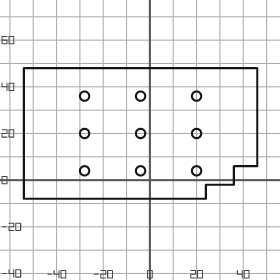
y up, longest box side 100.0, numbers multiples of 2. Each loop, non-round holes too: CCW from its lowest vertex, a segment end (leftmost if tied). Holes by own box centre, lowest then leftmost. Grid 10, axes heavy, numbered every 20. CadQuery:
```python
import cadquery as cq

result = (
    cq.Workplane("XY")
    .moveTo(-54.0, -8.0)
    .lineTo(24.0, -8.0)
    .lineTo(24.0, -2.0)
    .lineTo(36.0, -2.0)
    .lineTo(36.0, 6.0)
    .lineTo(46.0, 6.0)
    .lineTo(46.0, 48.0)
    .lineTo(-54.0, 48.0)
    .close()
    .moveTo(-28.0, 4.0)
    .circle(2.0)
    .moveTo(-4.0, 4.0)
    .circle(2.0)
    .moveTo(20.0, 4.0)
    .circle(2.0)
    .moveTo(-28.0, 20.0)
    .circle(2.0)
    .moveTo(-4.0, 20.0)
    .circle(2.0)
    .moveTo(20.0, 20.0)
    .circle(2.0)
    .moveTo(-28.0, 36.0)
    .circle(2.0)
    .moveTo(-4.0, 36.0)
    .circle(2.0)
    .moveTo(20.0, 36.0)
    .circle(2.0)
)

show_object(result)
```